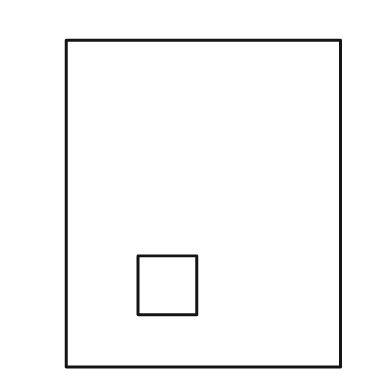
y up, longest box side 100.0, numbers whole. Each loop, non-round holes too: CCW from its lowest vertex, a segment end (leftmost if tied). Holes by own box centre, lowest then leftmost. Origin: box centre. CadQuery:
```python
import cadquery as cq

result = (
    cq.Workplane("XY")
    .moveTo(-42.0, -50.0)
    .lineTo(42.0, -50.0)
    .lineTo(42.0, 50.0)
    .lineTo(-42.0, 50.0)
    .close()
    .moveTo(-20.0, -34.0)
    .lineTo(-2.0, -34.0)
    .lineTo(-2.0, -16.0)
    .lineTo(-20.0, -16.0)
    .close()
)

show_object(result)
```